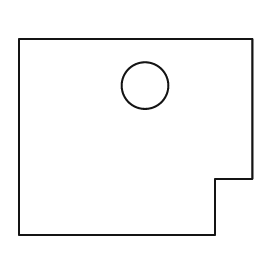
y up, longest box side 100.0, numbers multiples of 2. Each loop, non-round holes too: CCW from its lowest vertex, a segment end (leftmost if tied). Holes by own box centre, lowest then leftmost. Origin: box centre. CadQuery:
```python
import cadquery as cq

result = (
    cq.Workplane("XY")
    .moveTo(-50.0, -42.0)
    .lineTo(34.0, -42.0)
    .lineTo(34.0, -18.0)
    .lineTo(50.0, -18.0)
    .lineTo(50.0, 42.0)
    .lineTo(-50.0, 42.0)
    .close()
    .moveTo(4.0, 22.0)
    .circle(10.0)
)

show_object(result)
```